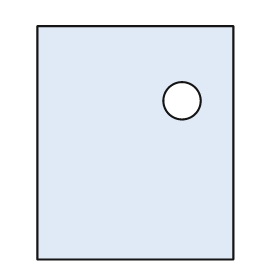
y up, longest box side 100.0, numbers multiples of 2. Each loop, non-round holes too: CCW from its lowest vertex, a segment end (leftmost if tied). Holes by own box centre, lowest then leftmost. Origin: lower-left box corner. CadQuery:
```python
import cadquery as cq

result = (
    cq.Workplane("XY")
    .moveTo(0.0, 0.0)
    .lineTo(84.0, 0.0)
    .lineTo(84.0, 100.0)
    .lineTo(0.0, 100.0)
    .close()
    .moveTo(62.0, 68.0)
    .circle(8.0)
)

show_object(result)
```